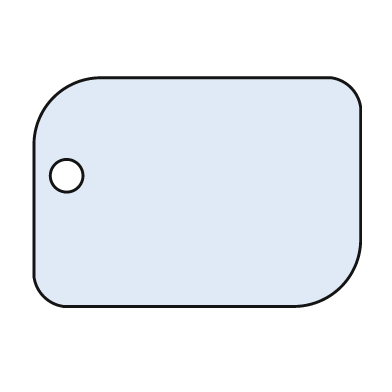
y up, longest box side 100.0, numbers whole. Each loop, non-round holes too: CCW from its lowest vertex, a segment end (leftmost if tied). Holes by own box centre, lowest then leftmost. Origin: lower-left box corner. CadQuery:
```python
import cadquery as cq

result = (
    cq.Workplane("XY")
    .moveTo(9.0, 0.0)
    .lineTo(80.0, 0.0)
    .threePointArc((94.0, 6.0), (100.0, 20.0))
    .lineTo(100.0, 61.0)
    .threePointArc((97.0, 67.0), (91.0, 70.0))
    .lineTo(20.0, 70.0)
    .threePointArc((6.0, 64.0), (0.0, 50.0))
    .lineTo(0.0, 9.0)
    .threePointArc((3.0, 3.0), (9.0, 0.0))
    .close()
    .moveTo(10.0, 40.0)
    .circle(5.0)
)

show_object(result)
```